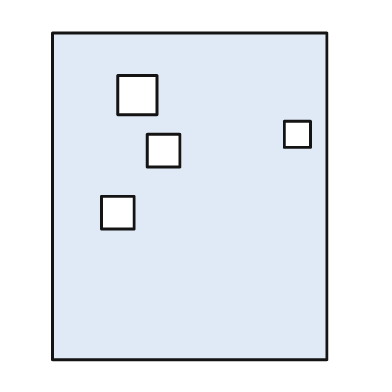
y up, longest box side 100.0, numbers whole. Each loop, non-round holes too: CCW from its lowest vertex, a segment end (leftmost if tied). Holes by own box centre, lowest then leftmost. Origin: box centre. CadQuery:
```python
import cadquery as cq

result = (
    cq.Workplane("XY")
    .moveTo(-42.0, -50.0)
    .lineTo(42.0, -50.0)
    .lineTo(42.0, 50.0)
    .lineTo(-42.0, 50.0)
    .close()
    .moveTo(-27.0, -10.0)
    .lineTo(-17.0, -10.0)
    .lineTo(-17.0, 0.0)
    .lineTo(-27.0, 0.0)
    .close()
    .moveTo(-13.0, 9.0)
    .lineTo(-3.0, 9.0)
    .lineTo(-3.0, 19.0)
    .lineTo(-13.0, 19.0)
    .close()
    .moveTo(29.0, 15.0)
    .lineTo(37.0, 15.0)
    .lineTo(37.0, 23.0)
    .lineTo(29.0, 23.0)
    .close()
    .moveTo(-22.0, 25.0)
    .lineTo(-10.0, 25.0)
    .lineTo(-10.0, 37.0)
    .lineTo(-22.0, 37.0)
    .close()
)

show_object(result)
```